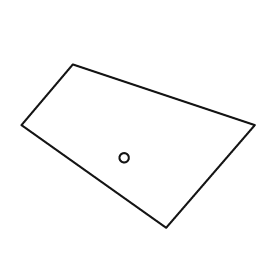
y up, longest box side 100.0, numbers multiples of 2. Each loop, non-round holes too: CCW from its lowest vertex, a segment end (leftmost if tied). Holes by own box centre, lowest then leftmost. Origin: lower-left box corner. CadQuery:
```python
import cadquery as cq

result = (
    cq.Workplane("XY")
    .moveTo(62.0, 0.0)
    .lineTo(100.0, 44.0)
    .lineTo(22.0, 70.0)
    .lineTo(0.0, 44.0)
    .close()
    .moveTo(44.0, 30.0)
    .circle(2.0)
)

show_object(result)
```